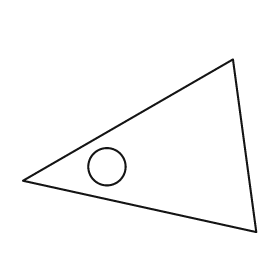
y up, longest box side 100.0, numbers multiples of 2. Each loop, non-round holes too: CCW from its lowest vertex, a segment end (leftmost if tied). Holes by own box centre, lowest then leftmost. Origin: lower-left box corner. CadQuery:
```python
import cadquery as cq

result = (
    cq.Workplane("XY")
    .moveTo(100.0, 0.0)
    .lineTo(90.0, 74.0)
    .lineTo(0.0, 22.0)
    .close()
    .moveTo(36.0, 28.0)
    .circle(8.0)
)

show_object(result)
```